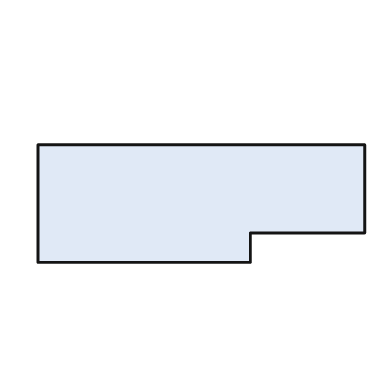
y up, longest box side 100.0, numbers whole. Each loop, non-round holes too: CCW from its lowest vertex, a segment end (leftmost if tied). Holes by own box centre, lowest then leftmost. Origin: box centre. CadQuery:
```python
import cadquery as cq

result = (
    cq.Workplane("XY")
    .moveTo(-50.0, -18.0)
    .lineTo(15.0, -18.0)
    .lineTo(15.0, -9.0)
    .lineTo(50.0, -9.0)
    .lineTo(50.0, 18.0)
    .lineTo(-50.0, 18.0)
    .close()
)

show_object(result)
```